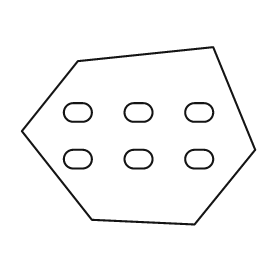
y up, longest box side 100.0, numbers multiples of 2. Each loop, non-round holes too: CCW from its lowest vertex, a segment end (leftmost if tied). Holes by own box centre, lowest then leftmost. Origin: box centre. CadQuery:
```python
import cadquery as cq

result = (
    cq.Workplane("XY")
    .moveTo(24.0, -38.0)
    .lineTo(50.0, -6.0)
    .lineTo(32.0, 38.0)
    .lineTo(-26.0, 32.0)
    .lineTo(-50.0, 2.0)
    .lineTo(-20.0, -36.0)
    .close()
    .moveTo(-28.0, -14.0)
    .lineTo(-24.0, -14.0)
    .threePointArc((-20.0, -10.0), (-24.0, -6.0))
    .lineTo(-28.0, -6.0)
    .threePointArc((-32.0, -10.0), (-28.0, -14.0))
    .close()
    .moveTo(-2.0, -14.0)
    .lineTo(2.0, -14.0)
    .threePointArc((6.0, -10.0), (2.0, -6.0))
    .lineTo(-2.0, -6.0)
    .threePointArc((-6.0, -10.0), (-2.0, -14.0))
    .close()
    .moveTo(24.0, -14.0)
    .lineTo(28.0, -14.0)
    .threePointArc((32.0, -10.0), (28.0, -6.0))
    .lineTo(24.0, -6.0)
    .threePointArc((20.0, -10.0), (24.0, -14.0))
    .close()
    .moveTo(-28.0, 6.0)
    .lineTo(-24.0, 6.0)
    .threePointArc((-20.0, 10.0), (-24.0, 14.0))
    .lineTo(-28.0, 14.0)
    .threePointArc((-32.0, 10.0), (-28.0, 6.0))
    .close()
    .moveTo(-2.0, 6.0)
    .lineTo(2.0, 6.0)
    .threePointArc((6.0, 10.0), (2.0, 14.0))
    .lineTo(-2.0, 14.0)
    .threePointArc((-6.0, 10.0), (-2.0, 6.0))
    .close()
    .moveTo(24.0, 6.0)
    .lineTo(28.0, 6.0)
    .threePointArc((32.0, 10.0), (28.0, 14.0))
    .lineTo(24.0, 14.0)
    .threePointArc((20.0, 10.0), (24.0, 6.0))
    .close()
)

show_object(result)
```